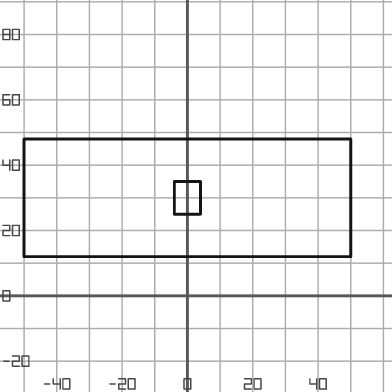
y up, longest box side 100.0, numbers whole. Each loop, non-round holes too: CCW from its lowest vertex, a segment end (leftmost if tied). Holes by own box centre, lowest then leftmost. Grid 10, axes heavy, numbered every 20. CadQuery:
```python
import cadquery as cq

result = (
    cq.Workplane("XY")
    .moveTo(-50.0, 12.0)
    .lineTo(50.0, 12.0)
    .lineTo(50.0, 48.0)
    .lineTo(-50.0, 48.0)
    .close()
    .moveTo(-4.0, 25.0)
    .lineTo(4.0, 25.0)
    .lineTo(4.0, 35.0)
    .lineTo(-4.0, 35.0)
    .close()
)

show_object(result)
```